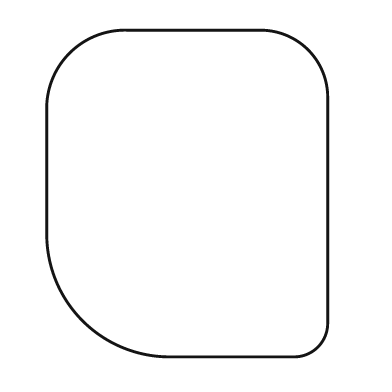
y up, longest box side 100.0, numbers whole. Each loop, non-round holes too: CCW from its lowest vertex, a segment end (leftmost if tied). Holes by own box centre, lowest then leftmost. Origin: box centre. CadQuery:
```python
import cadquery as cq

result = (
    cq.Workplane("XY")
    .moveTo(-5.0, -50.0)
    .lineTo(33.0, -50.0)
    .threePointArc((40.0, -47.0), (43.0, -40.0))
    .lineTo(43.0, 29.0)
    .threePointArc((37.0, 44.0), (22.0, 50.0))
    .lineTo(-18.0, 50.0)
    .threePointArc((-36.0, 43.0), (-43.0, 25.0))
    .lineTo(-43.0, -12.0)
    .threePointArc((-32.0, -39.0), (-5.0, -50.0))
    .close()
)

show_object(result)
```